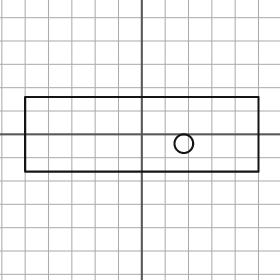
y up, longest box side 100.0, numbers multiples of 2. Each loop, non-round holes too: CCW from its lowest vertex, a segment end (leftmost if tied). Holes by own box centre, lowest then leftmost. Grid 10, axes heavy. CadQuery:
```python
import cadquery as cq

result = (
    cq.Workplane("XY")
    .moveTo(-50.0, -16.0)
    .lineTo(50.0, -16.0)
    .lineTo(50.0, 16.0)
    .lineTo(-50.0, 16.0)
    .close()
    .moveTo(18.0, -4.0)
    .circle(4.0)
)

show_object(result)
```